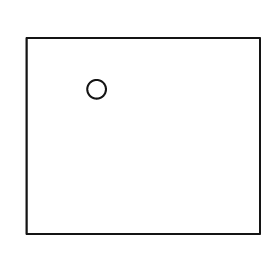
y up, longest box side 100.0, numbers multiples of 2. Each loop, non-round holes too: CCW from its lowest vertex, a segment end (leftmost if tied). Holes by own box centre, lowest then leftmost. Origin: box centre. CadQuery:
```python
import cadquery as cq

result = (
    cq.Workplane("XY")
    .moveTo(-50.0, -42.0)
    .lineTo(50.0, -42.0)
    .lineTo(50.0, 42.0)
    .lineTo(-50.0, 42.0)
    .close()
    .moveTo(-20.0, 20.0)
    .circle(4.0)
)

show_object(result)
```